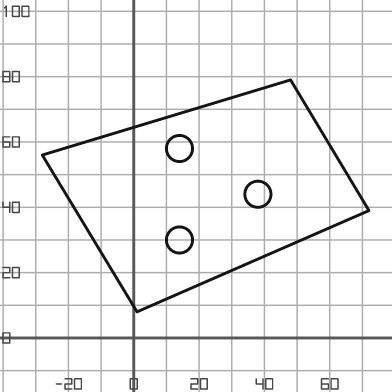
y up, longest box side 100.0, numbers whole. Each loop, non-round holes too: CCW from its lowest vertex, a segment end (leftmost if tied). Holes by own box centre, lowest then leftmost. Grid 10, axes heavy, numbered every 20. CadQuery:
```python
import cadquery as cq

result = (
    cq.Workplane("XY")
    .moveTo(1.0, 8.0)
    .lineTo(72.0, 39.0)
    .lineTo(48.0, 79.0)
    .lineTo(-28.0, 56.0)
    .close()
    .moveTo(14.0, 30.0)
    .circle(4.0)
    .moveTo(38.0, 44.0)
    .circle(4.0)
    .moveTo(14.0, 58.0)
    .circle(4.0)
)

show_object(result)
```